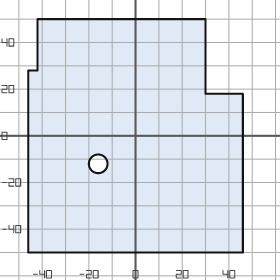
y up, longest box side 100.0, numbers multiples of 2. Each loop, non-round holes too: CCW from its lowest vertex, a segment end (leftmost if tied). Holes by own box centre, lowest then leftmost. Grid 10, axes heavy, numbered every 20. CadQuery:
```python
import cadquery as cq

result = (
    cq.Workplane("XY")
    .moveTo(-46.0, -50.0)
    .lineTo(46.0, -50.0)
    .lineTo(46.0, 18.0)
    .lineTo(30.0, 18.0)
    .lineTo(30.0, 50.0)
    .lineTo(-42.0, 50.0)
    .lineTo(-42.0, 28.0)
    .lineTo(-46.0, 28.0)
    .close()
    .moveTo(-16.0, -12.0)
    .circle(4.0)
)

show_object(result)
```